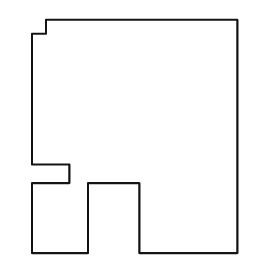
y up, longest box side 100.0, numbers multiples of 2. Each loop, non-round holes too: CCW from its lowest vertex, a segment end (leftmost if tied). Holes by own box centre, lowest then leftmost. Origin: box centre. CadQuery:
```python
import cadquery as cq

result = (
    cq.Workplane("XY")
    .moveTo(-44.0, -50.0)
    .lineTo(-20.0, -50.0)
    .lineTo(-20.0, -20.0)
    .lineTo(2.0, -20.0)
    .lineTo(2.0, -50.0)
    .lineTo(44.0, -50.0)
    .lineTo(44.0, 50.0)
    .lineTo(-38.0, 50.0)
    .lineTo(-38.0, 44.0)
    .lineTo(-44.0, 44.0)
    .lineTo(-44.0, -12.0)
    .lineTo(-28.0, -12.0)
    .lineTo(-28.0, -20.0)
    .lineTo(-44.0, -20.0)
    .close()
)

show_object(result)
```